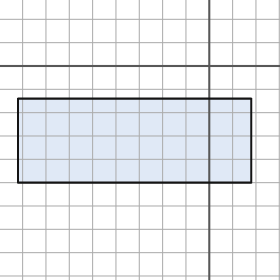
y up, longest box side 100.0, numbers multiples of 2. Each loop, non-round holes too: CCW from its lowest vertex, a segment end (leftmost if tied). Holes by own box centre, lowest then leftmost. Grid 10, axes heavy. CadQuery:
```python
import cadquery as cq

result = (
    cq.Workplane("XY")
    .moveTo(-82.0, -50.0)
    .lineTo(18.0, -50.0)
    .lineTo(18.0, -14.0)
    .lineTo(-82.0, -14.0)
    .close()
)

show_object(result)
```